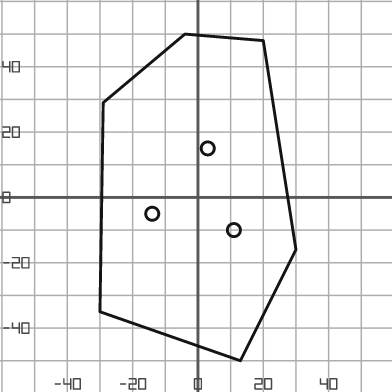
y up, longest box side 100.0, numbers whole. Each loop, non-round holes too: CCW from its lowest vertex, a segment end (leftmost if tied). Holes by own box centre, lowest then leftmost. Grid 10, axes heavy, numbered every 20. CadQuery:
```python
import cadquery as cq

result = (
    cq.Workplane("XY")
    .moveTo(13.0, -50.0)
    .lineTo(30.0, -16.0)
    .lineTo(20.0, 48.0)
    .lineTo(-4.0, 50.0)
    .lineTo(-29.0, 29.0)
    .lineTo(-30.0, -35.0)
    .close()
    .moveTo(11.0, -10.0)
    .circle(2.0)
    .moveTo(-14.0, -5.0)
    .circle(2.0)
    .moveTo(3.0, 15.0)
    .circle(2.0)
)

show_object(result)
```